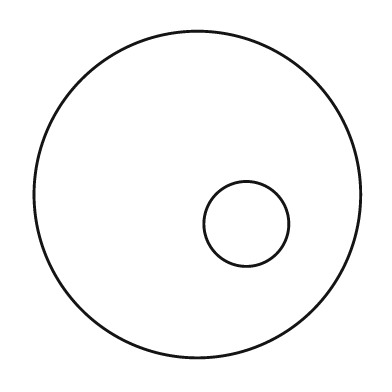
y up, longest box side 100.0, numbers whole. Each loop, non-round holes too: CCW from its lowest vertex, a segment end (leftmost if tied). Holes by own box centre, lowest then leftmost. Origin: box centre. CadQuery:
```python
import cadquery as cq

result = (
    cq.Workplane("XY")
    .moveTo(0.0, 0.0)
    .circle(50.0)
    .moveTo(15.0, -9.0)
    .circle(13.0)
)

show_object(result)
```